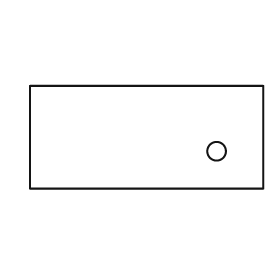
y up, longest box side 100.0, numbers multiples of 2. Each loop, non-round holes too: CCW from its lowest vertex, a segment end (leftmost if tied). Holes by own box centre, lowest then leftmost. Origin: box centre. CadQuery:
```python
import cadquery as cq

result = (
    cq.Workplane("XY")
    .moveTo(-50.0, -22.0)
    .lineTo(50.0, -22.0)
    .lineTo(50.0, 22.0)
    .lineTo(-50.0, 22.0)
    .close()
    .moveTo(30.0, -6.0)
    .circle(4.0)
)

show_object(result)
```